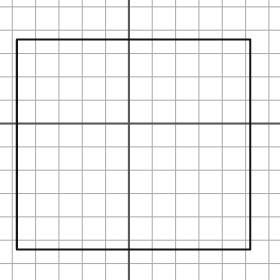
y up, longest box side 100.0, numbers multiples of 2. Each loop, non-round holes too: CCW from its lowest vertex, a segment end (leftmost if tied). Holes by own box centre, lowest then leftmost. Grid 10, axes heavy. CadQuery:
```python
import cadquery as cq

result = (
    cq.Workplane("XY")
    .moveTo(-48.0, -54.0)
    .lineTo(52.0, -54.0)
    .lineTo(52.0, 36.0)
    .lineTo(-48.0, 36.0)
    .close()
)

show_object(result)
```